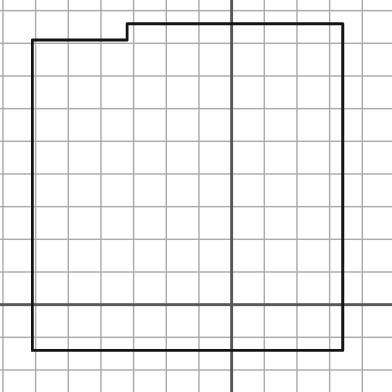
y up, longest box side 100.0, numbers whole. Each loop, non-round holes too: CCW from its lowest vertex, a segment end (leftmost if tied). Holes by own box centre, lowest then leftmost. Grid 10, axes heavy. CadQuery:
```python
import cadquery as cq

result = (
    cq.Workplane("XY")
    .moveTo(-61.0, -14.0)
    .lineTo(34.0, -14.0)
    .lineTo(34.0, 86.0)
    .lineTo(-32.0, 86.0)
    .lineTo(-32.0, 81.0)
    .lineTo(-61.0, 81.0)
    .close()
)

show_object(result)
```